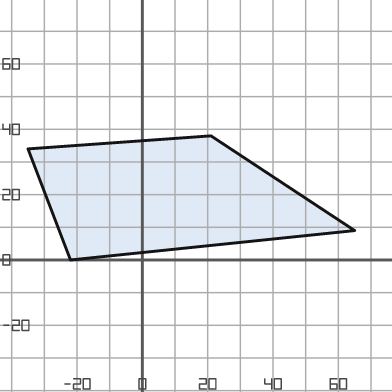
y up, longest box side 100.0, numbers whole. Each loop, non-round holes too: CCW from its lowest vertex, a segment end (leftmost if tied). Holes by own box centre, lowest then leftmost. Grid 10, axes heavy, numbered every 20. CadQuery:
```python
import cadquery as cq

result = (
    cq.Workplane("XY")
    .moveTo(-22.0, 0.0)
    .lineTo(65.0, 9.0)
    .lineTo(21.0, 38.0)
    .lineTo(-35.0, 34.0)
    .close()
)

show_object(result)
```